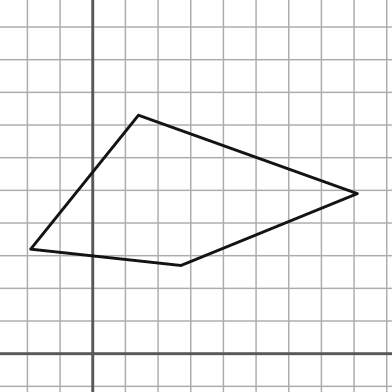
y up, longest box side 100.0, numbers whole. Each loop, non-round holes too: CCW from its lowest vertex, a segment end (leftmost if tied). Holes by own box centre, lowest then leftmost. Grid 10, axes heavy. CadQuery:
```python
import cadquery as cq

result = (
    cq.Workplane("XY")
    .moveTo(27.0, 27.0)
    .lineTo(81.0, 49.0)
    .lineTo(14.0, 73.0)
    .lineTo(-19.0, 32.0)
    .close()
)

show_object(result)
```